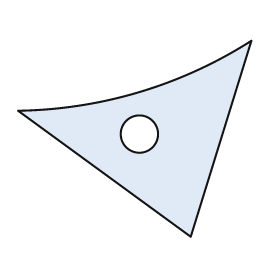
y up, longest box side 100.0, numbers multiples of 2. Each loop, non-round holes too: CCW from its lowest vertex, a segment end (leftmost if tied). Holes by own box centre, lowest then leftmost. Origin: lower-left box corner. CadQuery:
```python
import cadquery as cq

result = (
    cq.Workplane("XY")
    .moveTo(74.0, 0.0)
    .lineTo(100.0, 84.0)
    .threePointArc((52.0, 62.0), (0.0, 54.0))
    .close()
    .moveTo(52.0, 44.0)
    .circle(8.0)
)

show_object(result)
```